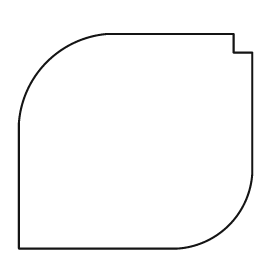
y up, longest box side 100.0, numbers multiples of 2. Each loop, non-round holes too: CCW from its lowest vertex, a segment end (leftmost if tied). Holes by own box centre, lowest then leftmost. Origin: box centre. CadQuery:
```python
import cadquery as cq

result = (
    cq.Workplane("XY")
    .moveTo(-50.0, -46.0)
    .lineTo(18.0, -46.0)
    .threePointArc((40.0, -36.0), (50.0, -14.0))
    .lineTo(50.0, 38.0)
    .lineTo(42.0, 38.0)
    .lineTo(42.0, 46.0)
    .lineTo(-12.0, 46.0)
    .threePointArc((-38.0, 34.0), (-50.0, 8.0))
    .close()
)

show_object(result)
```